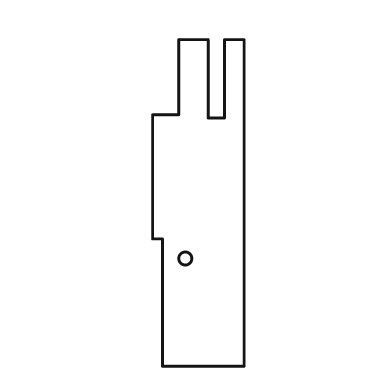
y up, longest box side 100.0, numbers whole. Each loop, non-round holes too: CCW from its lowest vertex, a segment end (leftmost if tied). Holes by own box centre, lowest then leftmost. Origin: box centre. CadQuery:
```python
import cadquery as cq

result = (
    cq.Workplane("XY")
    .moveTo(-11.0, -50.0)
    .lineTo(14.0, -50.0)
    .lineTo(14.0, 50.0)
    .lineTo(8.0, 50.0)
    .lineTo(8.0, 26.0)
    .lineTo(3.0, 26.0)
    .lineTo(3.0, 50.0)
    .lineTo(-6.0, 50.0)
    .lineTo(-6.0, 27.0)
    .lineTo(-14.0, 27.0)
    .lineTo(-14.0, -11.0)
    .lineTo(-11.0, -11.0)
    .close()
    .moveTo(-4.0, -17.0)
    .circle(2.0)
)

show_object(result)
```